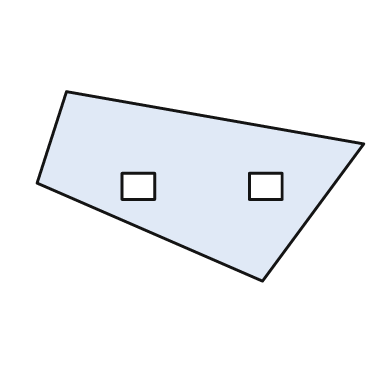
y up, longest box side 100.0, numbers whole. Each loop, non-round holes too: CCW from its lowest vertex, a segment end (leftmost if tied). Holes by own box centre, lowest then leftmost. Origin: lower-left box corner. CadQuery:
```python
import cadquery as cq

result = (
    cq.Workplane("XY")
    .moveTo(69.0, 0.0)
    .lineTo(100.0, 42.0)
    .lineTo(9.0, 58.0)
    .lineTo(0.0, 30.0)
    .close()
    .moveTo(26.0, 25.0)
    .lineTo(36.0, 25.0)
    .lineTo(36.0, 33.0)
    .lineTo(26.0, 33.0)
    .close()
    .moveTo(65.0, 25.0)
    .lineTo(75.0, 25.0)
    .lineTo(75.0, 33.0)
    .lineTo(65.0, 33.0)
    .close()
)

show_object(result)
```